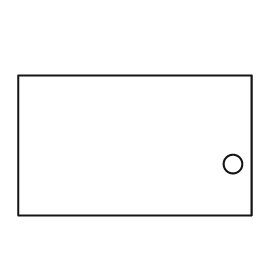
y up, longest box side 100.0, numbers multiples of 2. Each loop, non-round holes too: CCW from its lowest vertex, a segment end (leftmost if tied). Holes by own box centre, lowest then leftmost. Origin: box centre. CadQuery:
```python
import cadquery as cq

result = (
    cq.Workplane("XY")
    .moveTo(-50.0, -30.0)
    .lineTo(50.0, -30.0)
    .lineTo(50.0, 30.0)
    .lineTo(-50.0, 30.0)
    .close()
    .moveTo(42.0, -8.0)
    .circle(4.0)
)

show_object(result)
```